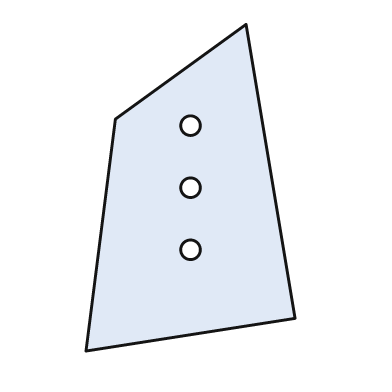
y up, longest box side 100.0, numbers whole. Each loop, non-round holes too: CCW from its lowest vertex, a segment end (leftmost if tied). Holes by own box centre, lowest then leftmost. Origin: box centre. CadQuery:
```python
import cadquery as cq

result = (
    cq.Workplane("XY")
    .moveTo(-32.0, -50.0)
    .lineTo(32.0, -40.0)
    .lineTo(17.0, 50.0)
    .lineTo(-23.0, 21.0)
    .close()
    .moveTo(0.0, -19.0)
    .circle(3.0)
    .moveTo(0.0, 0.0)
    .circle(3.0)
    .moveTo(0.0, 19.0)
    .circle(3.0)
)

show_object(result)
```